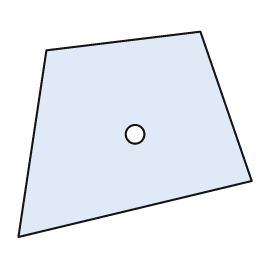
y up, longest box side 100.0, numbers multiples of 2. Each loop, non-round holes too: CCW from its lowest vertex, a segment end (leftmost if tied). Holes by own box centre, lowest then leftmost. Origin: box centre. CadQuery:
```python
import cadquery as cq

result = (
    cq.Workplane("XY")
    .moveTo(-50.0, -44.0)
    .lineTo(50.0, -20.0)
    .lineTo(28.0, 44.0)
    .lineTo(-38.0, 36.0)
    .close()
    .moveTo(0.0, 0.0)
    .circle(4.0)
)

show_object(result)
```